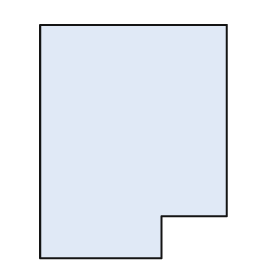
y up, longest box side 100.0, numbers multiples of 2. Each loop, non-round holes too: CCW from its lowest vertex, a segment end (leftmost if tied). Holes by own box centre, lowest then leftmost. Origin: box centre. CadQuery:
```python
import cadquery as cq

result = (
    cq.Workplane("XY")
    .moveTo(-40.0, -50.0)
    .lineTo(12.0, -50.0)
    .lineTo(12.0, -32.0)
    .lineTo(40.0, -32.0)
    .lineTo(40.0, 50.0)
    .lineTo(-40.0, 50.0)
    .close()
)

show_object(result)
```